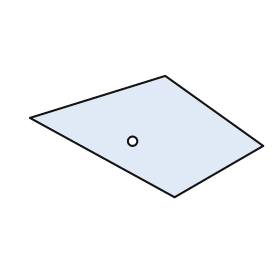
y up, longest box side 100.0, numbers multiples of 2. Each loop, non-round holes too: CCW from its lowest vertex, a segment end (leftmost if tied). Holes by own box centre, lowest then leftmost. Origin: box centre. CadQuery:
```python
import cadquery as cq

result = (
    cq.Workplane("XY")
    .moveTo(12.0, -26.0)
    .lineTo(50.0, -4.0)
    .lineTo(8.0, 26.0)
    .lineTo(-50.0, 8.0)
    .close()
    .moveTo(-6.0, -2.0)
    .circle(2.0)
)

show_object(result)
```